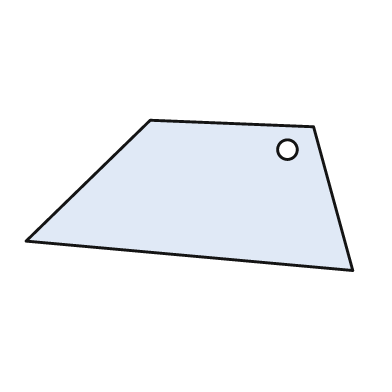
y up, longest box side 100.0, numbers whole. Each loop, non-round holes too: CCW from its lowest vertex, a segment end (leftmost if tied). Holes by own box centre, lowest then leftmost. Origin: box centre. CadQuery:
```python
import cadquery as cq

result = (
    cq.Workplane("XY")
    .moveTo(50.0, -23.0)
    .lineTo(38.0, 21.0)
    .lineTo(-12.0, 23.0)
    .lineTo(-50.0, -14.0)
    .close()
    .moveTo(30.0, 14.0)
    .circle(3.0)
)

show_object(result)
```